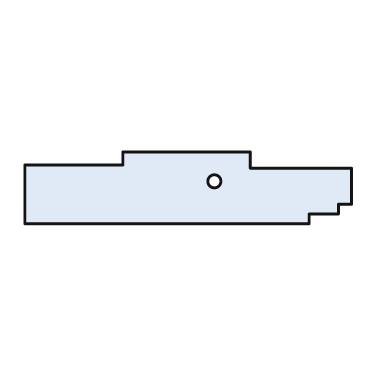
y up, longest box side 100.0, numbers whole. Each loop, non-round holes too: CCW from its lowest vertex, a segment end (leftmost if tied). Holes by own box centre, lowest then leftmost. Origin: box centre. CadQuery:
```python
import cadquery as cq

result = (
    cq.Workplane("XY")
    .moveTo(-50.0, -11.0)
    .lineTo(37.0, -11.0)
    .lineTo(37.0, -8.0)
    .lineTo(46.0, -8.0)
    .lineTo(46.0, -5.0)
    .lineTo(50.0, -5.0)
    .lineTo(50.0, 6.0)
    .lineTo(19.0, 6.0)
    .lineTo(19.0, 11.0)
    .lineTo(-20.0, 11.0)
    .lineTo(-20.0, 7.0)
    .lineTo(-50.0, 7.0)
    .close()
    .moveTo(8.0, 2.0)
    .circle(2.0)
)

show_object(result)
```